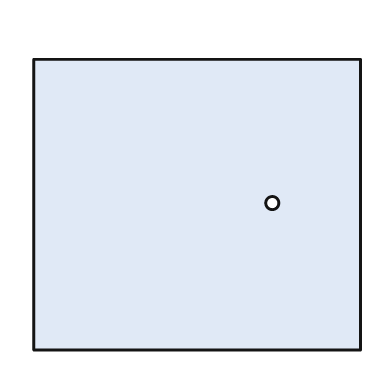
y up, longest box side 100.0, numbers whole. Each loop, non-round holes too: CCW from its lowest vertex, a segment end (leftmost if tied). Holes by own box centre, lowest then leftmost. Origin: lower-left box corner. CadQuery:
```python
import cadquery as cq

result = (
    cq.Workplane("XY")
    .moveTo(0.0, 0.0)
    .lineTo(100.0, 0.0)
    .lineTo(100.0, 89.0)
    .lineTo(0.0, 89.0)
    .close()
    .moveTo(73.0, 45.0)
    .circle(2.0)
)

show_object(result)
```